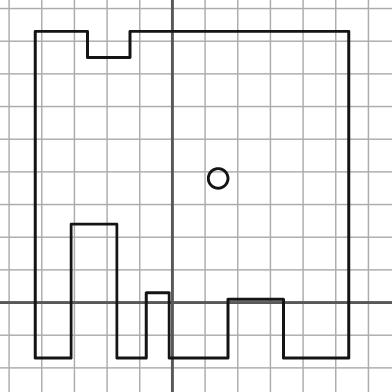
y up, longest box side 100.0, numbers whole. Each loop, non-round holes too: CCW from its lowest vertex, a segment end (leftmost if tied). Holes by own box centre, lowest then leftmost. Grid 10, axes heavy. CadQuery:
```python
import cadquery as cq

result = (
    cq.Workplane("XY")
    .moveTo(-42.0, -17.0)
    .lineTo(-31.0, -17.0)
    .lineTo(-31.0, 24.0)
    .lineTo(-17.0, 24.0)
    .lineTo(-17.0, -17.0)
    .lineTo(-8.0, -17.0)
    .lineTo(-8.0, 3.0)
    .lineTo(-1.0, 3.0)
    .lineTo(-1.0, -17.0)
    .lineTo(17.0, -17.0)
    .lineTo(17.0, 1.0)
    .lineTo(34.0, 1.0)
    .lineTo(34.0, -17.0)
    .lineTo(54.0, -17.0)
    .lineTo(54.0, 83.0)
    .lineTo(-13.0, 83.0)
    .lineTo(-13.0, 75.0)
    .lineTo(-26.0, 75.0)
    .lineTo(-26.0, 83.0)
    .lineTo(-42.0, 83.0)
    .close()
    .moveTo(14.0, 38.0)
    .circle(3.0)
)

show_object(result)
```